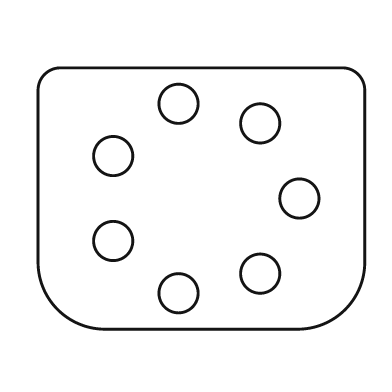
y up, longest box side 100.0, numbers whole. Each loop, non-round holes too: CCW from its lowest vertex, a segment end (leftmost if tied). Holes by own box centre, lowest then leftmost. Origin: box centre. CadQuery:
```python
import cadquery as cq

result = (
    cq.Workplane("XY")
    .moveTo(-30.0, -40.0)
    .lineTo(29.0, -40.0)
    .threePointArc((44.0, -34.0), (50.0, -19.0))
    .lineTo(50.0, 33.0)
    .threePointArc((48.0, 38.0), (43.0, 40.0))
    .lineTo(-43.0, 40.0)
    .threePointArc((-48.0, 38.0), (-50.0, 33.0))
    .lineTo(-50.0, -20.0)
    .threePointArc((-44.0, -34.0), (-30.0, -40.0))
    .close()
    .moveTo(-7.0, -29.0)
    .circle(6.0)
    .moveTo(18.0, -23.0)
    .circle(6.0)
    .moveTo(-27.0, -13.0)
    .circle(6.0)
    .moveTo(30.0, 0.0)
    .circle(6.0)
    .moveTo(-27.0, 13.0)
    .circle(6.0)
    .moveTo(18.0, 23.0)
    .circle(6.0)
    .moveTo(-7.0, 29.0)
    .circle(6.0)
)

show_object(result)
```